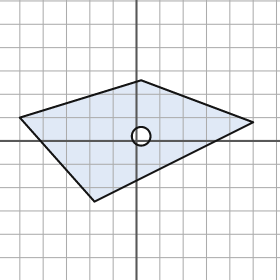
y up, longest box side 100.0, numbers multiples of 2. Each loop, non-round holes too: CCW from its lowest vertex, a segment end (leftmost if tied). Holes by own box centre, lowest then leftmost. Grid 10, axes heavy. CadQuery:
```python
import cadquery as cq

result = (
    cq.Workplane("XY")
    .moveTo(-18.0, -26.0)
    .lineTo(50.0, 8.0)
    .lineTo(2.0, 26.0)
    .lineTo(-50.0, 10.0)
    .close()
    .moveTo(2.0, 2.0)
    .circle(4.0)
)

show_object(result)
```